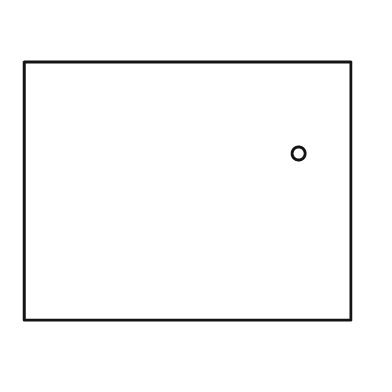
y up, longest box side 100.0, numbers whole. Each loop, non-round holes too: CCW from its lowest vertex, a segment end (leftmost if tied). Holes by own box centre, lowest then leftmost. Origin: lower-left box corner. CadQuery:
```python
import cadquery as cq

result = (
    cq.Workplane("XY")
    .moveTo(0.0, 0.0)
    .lineTo(100.0, 0.0)
    .lineTo(100.0, 79.0)
    .lineTo(0.0, 79.0)
    .close()
    .moveTo(84.0, 51.0)
    .circle(2.0)
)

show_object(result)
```